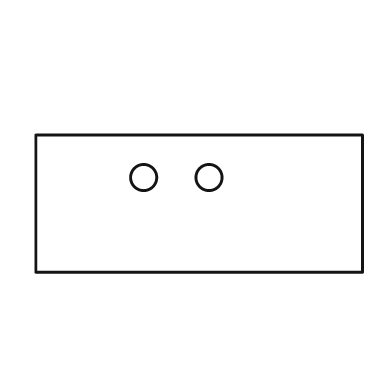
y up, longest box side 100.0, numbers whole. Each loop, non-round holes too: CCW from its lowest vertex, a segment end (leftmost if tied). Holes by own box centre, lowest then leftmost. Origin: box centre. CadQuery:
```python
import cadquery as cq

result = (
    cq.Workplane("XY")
    .moveTo(-50.0, -21.0)
    .lineTo(50.0, -21.0)
    .lineTo(50.0, 21.0)
    .lineTo(-50.0, 21.0)
    .close()
    .moveTo(-17.0, 8.0)
    .circle(4.0)
    .moveTo(3.0, 8.0)
    .circle(4.0)
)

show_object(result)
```